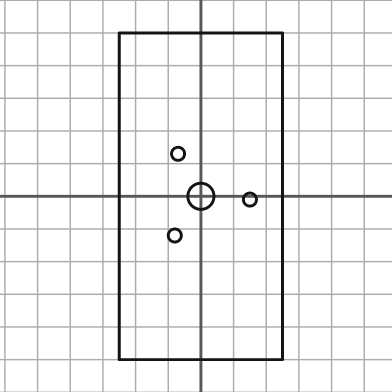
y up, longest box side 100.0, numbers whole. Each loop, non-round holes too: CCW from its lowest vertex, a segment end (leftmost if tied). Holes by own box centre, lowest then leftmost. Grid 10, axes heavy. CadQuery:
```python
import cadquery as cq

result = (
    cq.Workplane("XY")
    .moveTo(-25.0, -50.0)
    .lineTo(25.0, -50.0)
    .lineTo(25.0, 50.0)
    .lineTo(-25.0, 50.0)
    .close()
    .moveTo(-8.0, -12.0)
    .circle(2.0)
    .moveTo(15.0, -1.0)
    .circle(2.0)
    .moveTo(0.0, 0.0)
    .circle(4.0)
    .moveTo(-7.0, 13.0)
    .circle(2.0)
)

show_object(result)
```